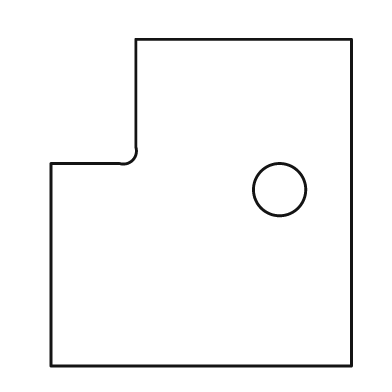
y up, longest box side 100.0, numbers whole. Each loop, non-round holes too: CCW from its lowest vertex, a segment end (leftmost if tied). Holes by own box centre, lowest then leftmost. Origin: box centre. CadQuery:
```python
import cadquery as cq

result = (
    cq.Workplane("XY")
    .moveTo(-46.0, -50.0)
    .lineTo(46.0, -50.0)
    .lineTo(46.0, 50.0)
    .lineTo(-20.0, 50.0)
    .lineTo(-20.0, 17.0)
    .threePointArc((-21.0, 13.0), (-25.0, 12.0))
    .lineTo(-46.0, 12.0)
    .close()
    .moveTo(24.0, 4.0)
    .circle(8.0)
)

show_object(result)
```